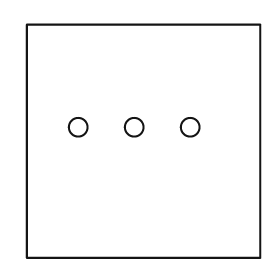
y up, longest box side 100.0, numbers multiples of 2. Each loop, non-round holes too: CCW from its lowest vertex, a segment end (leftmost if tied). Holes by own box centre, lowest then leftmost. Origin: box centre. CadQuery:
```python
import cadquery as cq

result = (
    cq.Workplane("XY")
    .moveTo(-50.0, -50.0)
    .lineTo(50.0, -50.0)
    .lineTo(50.0, 50.0)
    .lineTo(-50.0, 50.0)
    .close()
    .moveTo(-28.0, 6.0)
    .circle(4.0)
    .moveTo(-4.0, 6.0)
    .circle(4.0)
    .moveTo(20.0, 6.0)
    .circle(4.0)
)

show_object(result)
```